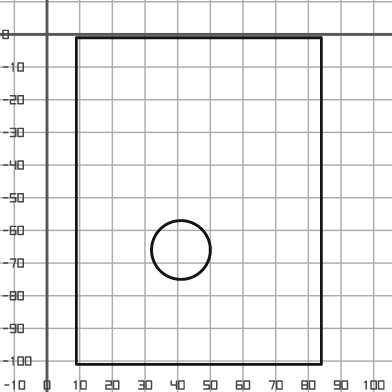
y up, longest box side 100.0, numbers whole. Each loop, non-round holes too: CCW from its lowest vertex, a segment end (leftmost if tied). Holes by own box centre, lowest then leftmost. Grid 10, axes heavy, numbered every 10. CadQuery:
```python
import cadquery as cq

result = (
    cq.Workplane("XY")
    .moveTo(9.0, -101.0)
    .lineTo(84.0, -101.0)
    .lineTo(84.0, -1.0)
    .lineTo(9.0, -1.0)
    .close()
    .moveTo(41.0, -66.0)
    .circle(9.0)
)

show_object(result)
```